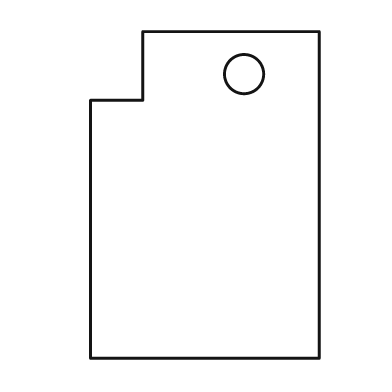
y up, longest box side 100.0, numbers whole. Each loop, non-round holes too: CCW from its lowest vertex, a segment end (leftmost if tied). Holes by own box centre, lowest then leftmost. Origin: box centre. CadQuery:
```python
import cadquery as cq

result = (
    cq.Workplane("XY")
    .moveTo(-35.0, -50.0)
    .lineTo(35.0, -50.0)
    .lineTo(35.0, 50.0)
    .lineTo(-19.0, 50.0)
    .lineTo(-19.0, 29.0)
    .lineTo(-35.0, 29.0)
    .close()
    .moveTo(12.0, 37.0)
    .circle(6.0)
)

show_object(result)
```